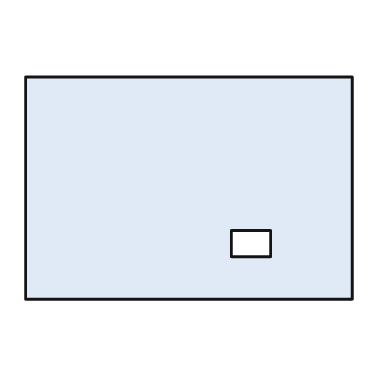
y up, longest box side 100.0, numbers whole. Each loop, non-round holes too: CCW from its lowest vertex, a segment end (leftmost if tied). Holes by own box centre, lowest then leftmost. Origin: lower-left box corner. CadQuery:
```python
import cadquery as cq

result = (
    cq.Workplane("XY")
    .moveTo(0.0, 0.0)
    .lineTo(100.0, 0.0)
    .lineTo(100.0, 68.0)
    .lineTo(0.0, 68.0)
    .close()
    .moveTo(63.0, 13.0)
    .lineTo(75.0, 13.0)
    .lineTo(75.0, 21.0)
    .lineTo(63.0, 21.0)
    .close()
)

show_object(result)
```